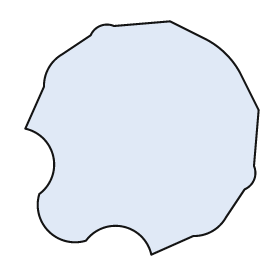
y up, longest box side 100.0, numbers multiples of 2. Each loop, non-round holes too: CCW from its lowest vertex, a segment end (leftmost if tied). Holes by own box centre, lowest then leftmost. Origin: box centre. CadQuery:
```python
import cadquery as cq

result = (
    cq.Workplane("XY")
    .moveTo(4.0, -50.0)
    .lineTo(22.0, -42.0)
    .threePointArc((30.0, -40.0), (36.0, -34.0))
    .lineTo(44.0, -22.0)
    .threePointArc((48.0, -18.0), (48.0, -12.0))
    .lineTo(50.0, 12.0)
    .lineTo(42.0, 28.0)
    .threePointArc((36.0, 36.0), (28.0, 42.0))
    .lineTo(12.0, 50.0)
    .lineTo(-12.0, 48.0)
    .threePointArc((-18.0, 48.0), (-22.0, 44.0))
    .lineTo(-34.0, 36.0)
    .threePointArc((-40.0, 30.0), (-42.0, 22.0))
    .lineTo(-50.0, 4.0)
    .threePointArc((-38.0, -8.0), (-44.0, -24.0))
    .threePointArc((-40.0, -40.0), (-24.0, -44.0))
    .threePointArc((-8.0, -38.0), (4.0, -50.0))
    .close()
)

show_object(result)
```